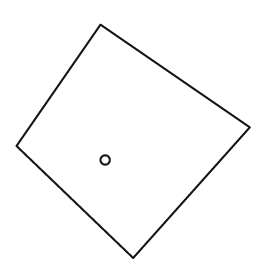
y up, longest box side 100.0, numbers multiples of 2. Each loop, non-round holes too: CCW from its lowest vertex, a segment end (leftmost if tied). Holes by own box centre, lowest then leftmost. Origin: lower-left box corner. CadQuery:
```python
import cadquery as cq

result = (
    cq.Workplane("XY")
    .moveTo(50.0, 0.0)
    .lineTo(100.0, 56.0)
    .lineTo(36.0, 100.0)
    .lineTo(0.0, 48.0)
    .close()
    .moveTo(38.0, 42.0)
    .circle(2.0)
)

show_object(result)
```